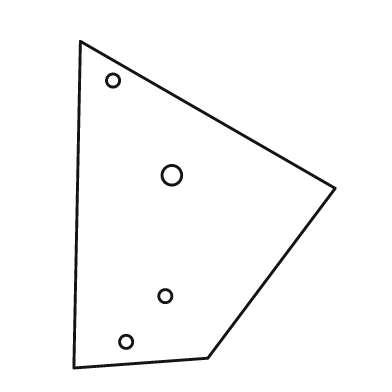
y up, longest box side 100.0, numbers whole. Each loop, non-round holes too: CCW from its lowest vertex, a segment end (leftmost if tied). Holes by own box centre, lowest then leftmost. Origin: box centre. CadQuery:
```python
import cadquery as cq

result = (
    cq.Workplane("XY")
    .moveTo(-40.0, -50.0)
    .lineTo(1.0, -47.0)
    .lineTo(40.0, 5.0)
    .lineTo(-38.0, 50.0)
    .close()
    .moveTo(-24.0, -42.0)
    .circle(2.0)
    .moveTo(-12.0, -28.0)
    .circle(2.0)
    .moveTo(-10.0, 9.0)
    .circle(3.0)
    .moveTo(-28.0, 38.0)
    .circle(2.0)
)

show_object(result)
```